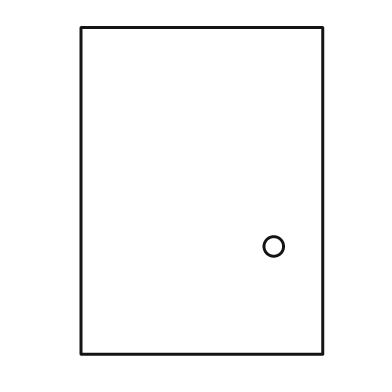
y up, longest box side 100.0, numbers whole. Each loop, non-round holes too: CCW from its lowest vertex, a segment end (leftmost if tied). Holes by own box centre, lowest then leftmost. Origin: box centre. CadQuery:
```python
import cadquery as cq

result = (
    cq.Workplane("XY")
    .moveTo(-37.0, -50.0)
    .lineTo(37.0, -50.0)
    .lineTo(37.0, 50.0)
    .lineTo(-37.0, 50.0)
    .close()
    .moveTo(22.0, -17.0)
    .circle(3.0)
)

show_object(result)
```